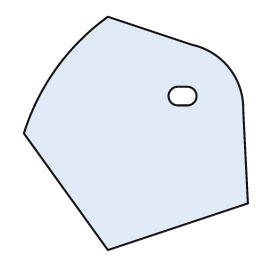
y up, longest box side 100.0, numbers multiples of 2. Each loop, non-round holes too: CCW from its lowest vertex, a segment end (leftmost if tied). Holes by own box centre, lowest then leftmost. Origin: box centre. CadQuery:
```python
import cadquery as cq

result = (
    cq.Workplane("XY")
    .moveTo(-12.0, -50.0)
    .lineTo(48.0, -30.0)
    .lineTo(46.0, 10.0)
    .threePointArc((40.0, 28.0), (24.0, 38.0))
    .lineTo(-12.0, 50.0)
    .threePointArc((-34.0, 28.0), (-48.0, 0.0))
    .close()
    .moveTo(18.0, 12.0)
    .lineTo(22.0, 12.0)
    .threePointArc((26.0, 16.0), (22.0, 20.0))
    .lineTo(18.0, 20.0)
    .threePointArc((14.0, 16.0), (18.0, 12.0))
    .close()
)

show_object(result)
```